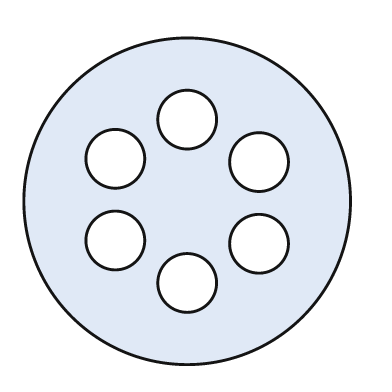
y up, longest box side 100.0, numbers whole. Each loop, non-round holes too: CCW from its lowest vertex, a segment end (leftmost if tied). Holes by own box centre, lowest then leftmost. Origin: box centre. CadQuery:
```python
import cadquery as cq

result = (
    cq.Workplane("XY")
    .moveTo(0.0, 0.0)
    .circle(50.0)
    .moveTo(0.0, -25.0)
    .circle(9.0)
    .moveTo(22.0, -13.0)
    .circle(9.0)
    .moveTo(-22.0, -12.0)
    .circle(9.0)
    .moveTo(22.0, 12.0)
    .circle(9.0)
    .moveTo(-22.0, 13.0)
    .circle(9.0)
    .moveTo(0.0, 25.0)
    .circle(9.0)
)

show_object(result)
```